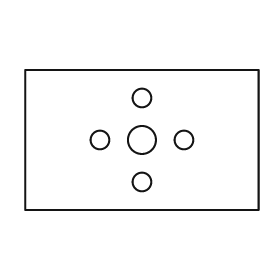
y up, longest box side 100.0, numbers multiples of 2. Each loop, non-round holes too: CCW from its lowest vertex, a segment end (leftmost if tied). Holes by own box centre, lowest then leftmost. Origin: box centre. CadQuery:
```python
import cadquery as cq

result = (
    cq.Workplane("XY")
    .moveTo(-50.0, -30.0)
    .lineTo(50.0, -30.0)
    .lineTo(50.0, 30.0)
    .lineTo(-50.0, 30.0)
    .close()
    .moveTo(0.0, -18.0)
    .circle(4.0)
    .moveTo(-18.0, 0.0)
    .circle(4.0)
    .moveTo(0.0, 0.0)
    .circle(6.0)
    .moveTo(18.0, 0.0)
    .circle(4.0)
    .moveTo(0.0, 18.0)
    .circle(4.0)
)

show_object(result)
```